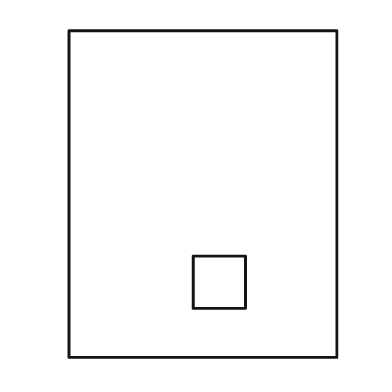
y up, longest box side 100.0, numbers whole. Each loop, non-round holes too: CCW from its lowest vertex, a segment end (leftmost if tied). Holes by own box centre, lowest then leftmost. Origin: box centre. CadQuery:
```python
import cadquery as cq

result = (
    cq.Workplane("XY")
    .moveTo(-41.0, -50.0)
    .lineTo(41.0, -50.0)
    .lineTo(41.0, 50.0)
    .lineTo(-41.0, 50.0)
    .close()
    .moveTo(-3.0, -35.0)
    .lineTo(13.0, -35.0)
    .lineTo(13.0, -19.0)
    .lineTo(-3.0, -19.0)
    .close()
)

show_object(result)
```